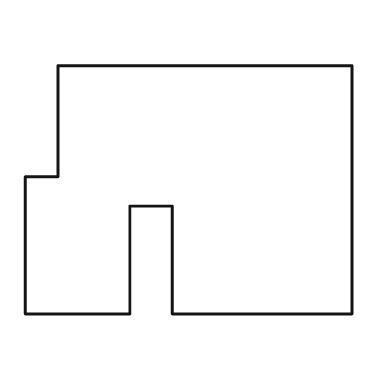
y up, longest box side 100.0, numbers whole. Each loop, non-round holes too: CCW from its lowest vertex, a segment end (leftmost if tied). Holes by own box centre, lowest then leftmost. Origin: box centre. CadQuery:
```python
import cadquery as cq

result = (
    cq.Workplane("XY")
    .moveTo(-50.0, -38.0)
    .lineTo(-18.0, -38.0)
    .lineTo(-18.0, -5.0)
    .lineTo(-5.0, -5.0)
    .lineTo(-5.0, -38.0)
    .lineTo(50.0, -38.0)
    .lineTo(50.0, 38.0)
    .lineTo(-40.0, 38.0)
    .lineTo(-40.0, 4.0)
    .lineTo(-50.0, 4.0)
    .close()
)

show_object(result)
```